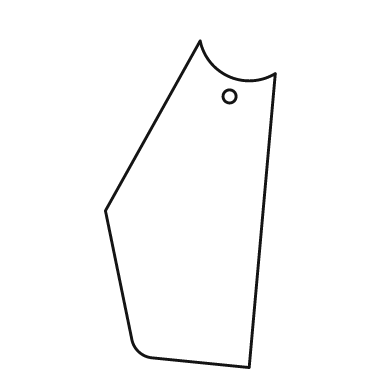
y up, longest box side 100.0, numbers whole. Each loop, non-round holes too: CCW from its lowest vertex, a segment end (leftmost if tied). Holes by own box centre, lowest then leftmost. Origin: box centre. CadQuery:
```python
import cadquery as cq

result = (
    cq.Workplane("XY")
    .moveTo(18.0, -50.0)
    .lineTo(26.0, 40.0)
    .threePointArc((12.0, 39.0), (3.0, 50.0))
    .lineTo(-26.0, -2.0)
    .lineTo(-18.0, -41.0)
    .threePointArc((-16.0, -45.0), (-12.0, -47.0))
    .close()
    .moveTo(12.0, 33.0)
    .circle(2.0)
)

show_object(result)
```